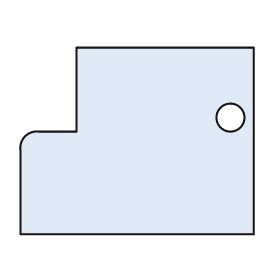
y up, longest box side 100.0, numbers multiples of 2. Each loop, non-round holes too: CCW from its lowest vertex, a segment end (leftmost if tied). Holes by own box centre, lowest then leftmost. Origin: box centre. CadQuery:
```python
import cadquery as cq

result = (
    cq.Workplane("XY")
    .moveTo(-50.0, -40.0)
    .lineTo(50.0, -40.0)
    .lineTo(50.0, 40.0)
    .lineTo(-26.0, 40.0)
    .lineTo(-26.0, 4.0)
    .lineTo(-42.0, 4.0)
    .threePointArc((-48.0, 2.0), (-50.0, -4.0))
    .close()
    .moveTo(40.0, 10.0)
    .circle(6.0)
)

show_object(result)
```